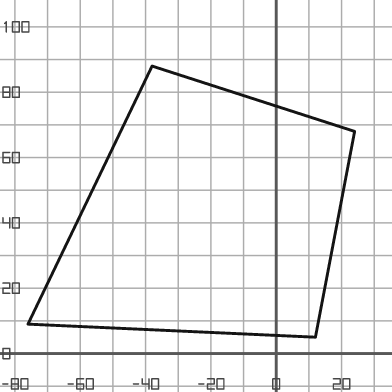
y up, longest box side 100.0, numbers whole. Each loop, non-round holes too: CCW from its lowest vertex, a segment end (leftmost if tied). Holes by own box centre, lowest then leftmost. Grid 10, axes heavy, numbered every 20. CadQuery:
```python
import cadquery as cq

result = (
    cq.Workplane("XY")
    .moveTo(12.0, 5.0)
    .lineTo(24.0, 68.0)
    .lineTo(-38.0, 88.0)
    .lineTo(-76.0, 9.0)
    .close()
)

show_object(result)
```